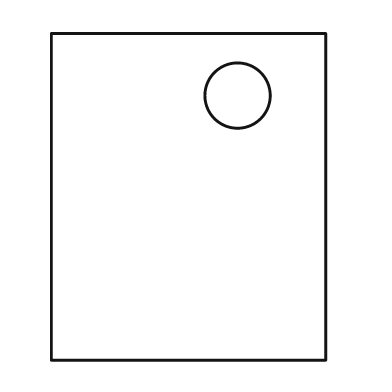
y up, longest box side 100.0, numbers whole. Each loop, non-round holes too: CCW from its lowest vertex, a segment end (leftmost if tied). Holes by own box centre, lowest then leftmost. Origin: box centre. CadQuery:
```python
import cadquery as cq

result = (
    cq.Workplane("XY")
    .moveTo(-42.0, -50.0)
    .lineTo(42.0, -50.0)
    .lineTo(42.0, 50.0)
    .lineTo(-42.0, 50.0)
    .close()
    .moveTo(15.0, 31.0)
    .circle(10.0)
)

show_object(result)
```